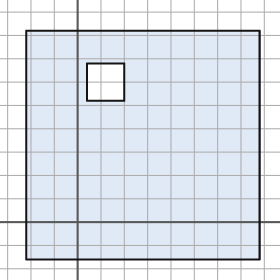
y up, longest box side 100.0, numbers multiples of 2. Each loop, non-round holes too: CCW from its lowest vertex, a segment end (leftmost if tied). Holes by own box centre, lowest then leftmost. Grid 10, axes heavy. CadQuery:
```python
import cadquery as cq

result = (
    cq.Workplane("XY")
    .moveTo(-22.0, -16.0)
    .lineTo(78.0, -16.0)
    .lineTo(78.0, 82.0)
    .lineTo(-22.0, 82.0)
    .close()
    .moveTo(4.0, 52.0)
    .lineTo(20.0, 52.0)
    .lineTo(20.0, 68.0)
    .lineTo(4.0, 68.0)
    .close()
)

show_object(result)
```